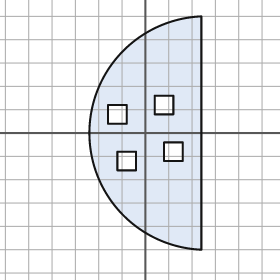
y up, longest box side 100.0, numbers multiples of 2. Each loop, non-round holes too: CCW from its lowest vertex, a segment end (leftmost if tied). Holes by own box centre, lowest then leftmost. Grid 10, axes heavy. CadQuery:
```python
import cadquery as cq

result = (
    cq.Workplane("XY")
    .moveTo(24.0, -50.0)
    .lineTo(24.0, 50.0)
    .threePointArc((-24.0, 0.0), (24.0, -50.0))
    .close()
    .moveTo(-12.0, -16.0)
    .lineTo(-4.0, -16.0)
    .lineTo(-4.0, -8.0)
    .lineTo(-12.0, -8.0)
    .close()
    .moveTo(8.0, -12.0)
    .lineTo(16.0, -12.0)
    .lineTo(16.0, -4.0)
    .lineTo(8.0, -4.0)
    .close()
    .moveTo(-16.0, 4.0)
    .lineTo(-8.0, 4.0)
    .lineTo(-8.0, 12.0)
    .lineTo(-16.0, 12.0)
    .close()
    .moveTo(4.0, 8.0)
    .lineTo(12.0, 8.0)
    .lineTo(12.0, 16.0)
    .lineTo(4.0, 16.0)
    .close()
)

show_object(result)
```